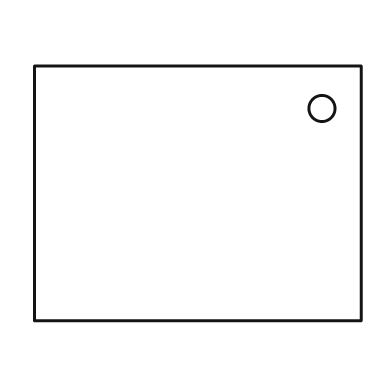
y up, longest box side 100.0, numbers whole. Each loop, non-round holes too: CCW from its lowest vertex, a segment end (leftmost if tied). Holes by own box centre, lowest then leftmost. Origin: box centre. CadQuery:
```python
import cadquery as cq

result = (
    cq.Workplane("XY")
    .moveTo(-50.0, -39.0)
    .lineTo(50.0, -39.0)
    .lineTo(50.0, 39.0)
    .lineTo(-50.0, 39.0)
    .close()
    .moveTo(38.0, 26.0)
    .circle(4.0)
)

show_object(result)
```